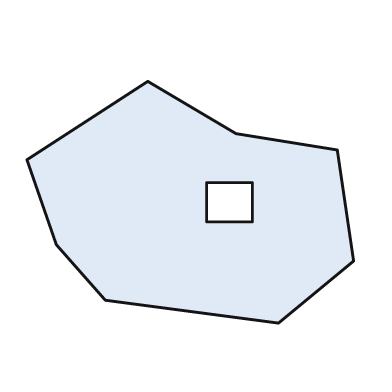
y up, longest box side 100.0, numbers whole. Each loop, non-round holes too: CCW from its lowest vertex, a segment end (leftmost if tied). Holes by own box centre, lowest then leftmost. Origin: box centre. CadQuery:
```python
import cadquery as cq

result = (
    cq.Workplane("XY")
    .moveTo(27.0, -37.0)
    .lineTo(50.0, -18.0)
    .lineTo(45.0, 16.0)
    .lineTo(14.0, 21.0)
    .lineTo(-13.0, 37.0)
    .lineTo(-50.0, 13.0)
    .lineTo(-41.0, -13.0)
    .lineTo(-26.0, -30.0)
    .close()
    .moveTo(5.0, -6.0)
    .lineTo(19.0, -6.0)
    .lineTo(19.0, 6.0)
    .lineTo(5.0, 6.0)
    .close()
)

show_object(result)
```